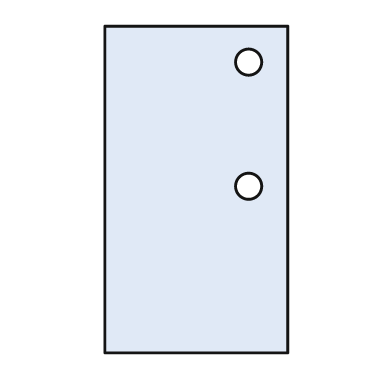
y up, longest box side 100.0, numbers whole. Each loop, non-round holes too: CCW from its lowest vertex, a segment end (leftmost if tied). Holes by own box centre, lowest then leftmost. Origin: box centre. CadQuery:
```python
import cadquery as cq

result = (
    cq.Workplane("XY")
    .moveTo(-28.0, -50.0)
    .lineTo(28.0, -50.0)
    .lineTo(28.0, 50.0)
    .lineTo(-28.0, 50.0)
    .close()
    .moveTo(16.0, 1.0)
    .circle(4.0)
    .moveTo(16.0, 39.0)
    .circle(4.0)
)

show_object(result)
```